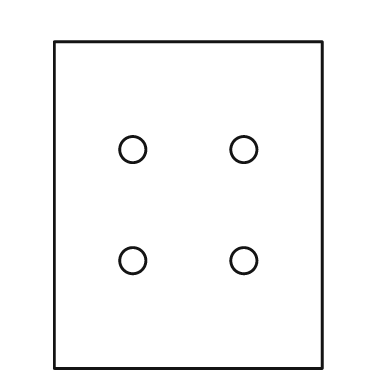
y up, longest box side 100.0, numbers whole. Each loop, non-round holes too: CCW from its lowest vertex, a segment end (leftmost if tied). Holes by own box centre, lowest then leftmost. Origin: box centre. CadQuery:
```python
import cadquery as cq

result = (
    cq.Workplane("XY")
    .moveTo(-41.0, -50.0)
    .lineTo(41.0, -50.0)
    .lineTo(41.0, 50.0)
    .lineTo(-41.0, 50.0)
    .close()
    .moveTo(-17.0, -17.0)
    .circle(4.0)
    .moveTo(17.0, -17.0)
    .circle(4.0)
    .moveTo(-17.0, 17.0)
    .circle(4.0)
    .moveTo(17.0, 17.0)
    .circle(4.0)
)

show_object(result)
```